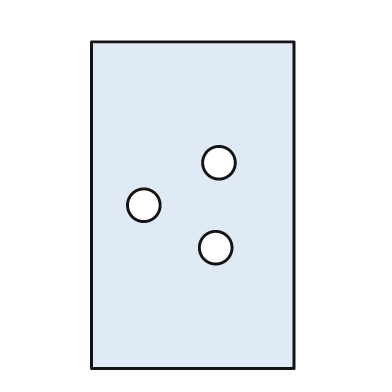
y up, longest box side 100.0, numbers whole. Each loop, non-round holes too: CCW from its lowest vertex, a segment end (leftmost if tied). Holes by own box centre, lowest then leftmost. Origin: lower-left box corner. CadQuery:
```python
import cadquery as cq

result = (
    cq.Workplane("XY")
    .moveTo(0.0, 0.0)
    .lineTo(62.0, 0.0)
    .lineTo(62.0, 100.0)
    .lineTo(0.0, 100.0)
    .close()
    .moveTo(38.0, 37.0)
    .circle(5.0)
    .moveTo(16.0, 50.0)
    .circle(5.0)
    .moveTo(39.0, 63.0)
    .circle(5.0)
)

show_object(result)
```